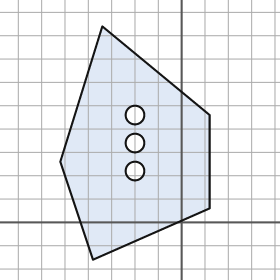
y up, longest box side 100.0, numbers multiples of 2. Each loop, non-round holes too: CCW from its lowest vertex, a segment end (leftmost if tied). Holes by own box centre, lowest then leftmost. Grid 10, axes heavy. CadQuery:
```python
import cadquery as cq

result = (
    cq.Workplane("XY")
    .moveTo(-38.0, -16.0)
    .lineTo(12.0, 6.0)
    .lineTo(12.0, 46.0)
    .lineTo(-34.0, 84.0)
    .lineTo(-52.0, 26.0)
    .close()
    .moveTo(-20.0, 22.0)
    .circle(4.0)
    .moveTo(-20.0, 34.0)
    .circle(4.0)
    .moveTo(-20.0, 46.0)
    .circle(4.0)
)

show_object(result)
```